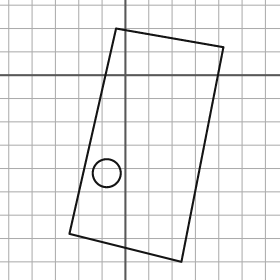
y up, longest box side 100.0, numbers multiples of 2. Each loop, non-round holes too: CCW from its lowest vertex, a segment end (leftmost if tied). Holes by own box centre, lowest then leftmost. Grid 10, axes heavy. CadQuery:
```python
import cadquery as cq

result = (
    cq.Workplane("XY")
    .moveTo(24.0, -80.0)
    .lineTo(42.0, 12.0)
    .lineTo(-4.0, 20.0)
    .lineTo(-24.0, -68.0)
    .close()
    .moveTo(-8.0, -42.0)
    .circle(6.0)
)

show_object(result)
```